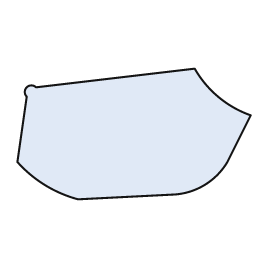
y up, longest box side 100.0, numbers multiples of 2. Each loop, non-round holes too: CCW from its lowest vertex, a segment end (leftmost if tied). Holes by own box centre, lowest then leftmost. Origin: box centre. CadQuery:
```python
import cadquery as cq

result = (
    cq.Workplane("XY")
    .moveTo(-24.0, -28.0)
    .lineTo(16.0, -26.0)
    .threePointArc((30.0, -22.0), (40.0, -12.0))
    .lineTo(50.0, 8.0)
    .threePointArc((36.0, 16.0), (26.0, 28.0))
    .lineTo(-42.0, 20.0)
    .threePointArc((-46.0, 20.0), (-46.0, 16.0))
    .lineTo(-50.0, -12.0)
    .threePointArc((-38.0, -22.0), (-24.0, -28.0))
    .close()
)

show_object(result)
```